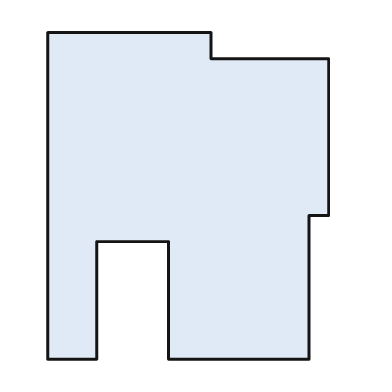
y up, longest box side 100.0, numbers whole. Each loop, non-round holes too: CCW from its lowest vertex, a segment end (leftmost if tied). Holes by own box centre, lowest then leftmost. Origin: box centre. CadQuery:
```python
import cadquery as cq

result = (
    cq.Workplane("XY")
    .moveTo(-43.0, -50.0)
    .lineTo(-28.0, -50.0)
    .lineTo(-28.0, -14.0)
    .lineTo(-6.0, -14.0)
    .lineTo(-6.0, -50.0)
    .lineTo(37.0, -50.0)
    .lineTo(37.0, -6.0)
    .lineTo(43.0, -6.0)
    .lineTo(43.0, 42.0)
    .lineTo(7.0, 42.0)
    .lineTo(7.0, 50.0)
    .lineTo(-43.0, 50.0)
    .close()
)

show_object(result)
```